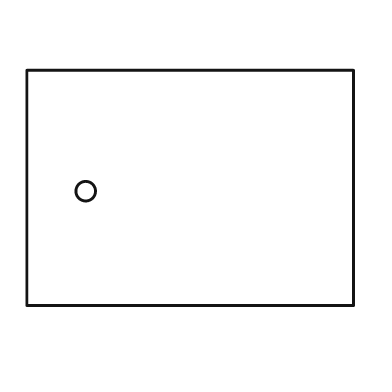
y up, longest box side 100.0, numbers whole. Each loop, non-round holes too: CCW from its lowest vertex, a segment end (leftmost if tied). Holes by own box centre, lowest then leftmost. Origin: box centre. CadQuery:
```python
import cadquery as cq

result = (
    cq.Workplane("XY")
    .moveTo(-50.0, -36.0)
    .lineTo(50.0, -36.0)
    .lineTo(50.0, 36.0)
    .lineTo(-50.0, 36.0)
    .close()
    .moveTo(-32.0, -1.0)
    .circle(3.0)
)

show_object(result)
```